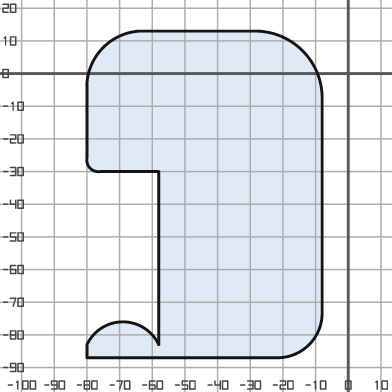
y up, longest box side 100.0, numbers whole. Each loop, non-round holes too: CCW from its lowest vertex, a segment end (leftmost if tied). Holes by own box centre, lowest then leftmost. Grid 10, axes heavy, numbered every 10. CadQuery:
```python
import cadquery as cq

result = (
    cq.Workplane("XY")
    .moveTo(-80.0, -87.0)
    .lineTo(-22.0, -87.0)
    .threePointArc((-12.0, -83.0), (-8.0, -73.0))
    .lineTo(-8.0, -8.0)
    .threePointArc((-14.0, 7.0), (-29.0, 13.0))
    .lineTo(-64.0, 13.0)
    .threePointArc((-75.0, 8.0), (-80.0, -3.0))
    .lineTo(-80.0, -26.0)
    .threePointArc((-79.0, -29.0), (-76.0, -30.0))
    .lineTo(-58.0, -30.0)
    .lineTo(-58.0, -83.0)
    .threePointArc((-69.0, -76.0), (-80.0, -83.0))
    .close()
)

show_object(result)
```